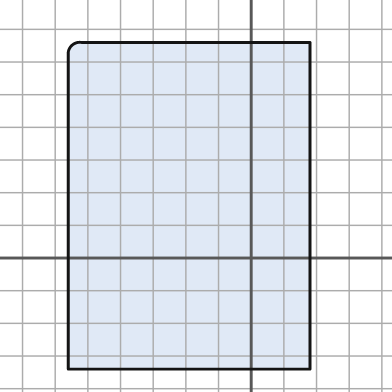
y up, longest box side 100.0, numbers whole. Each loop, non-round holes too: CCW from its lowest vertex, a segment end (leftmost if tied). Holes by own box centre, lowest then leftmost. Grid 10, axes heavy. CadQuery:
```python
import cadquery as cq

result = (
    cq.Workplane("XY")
    .moveTo(-56.0, -34.0)
    .lineTo(18.0, -34.0)
    .lineTo(18.0, 66.0)
    .lineTo(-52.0, 66.0)
    .threePointArc((-55.0, 65.0), (-56.0, 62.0))
    .close()
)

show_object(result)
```